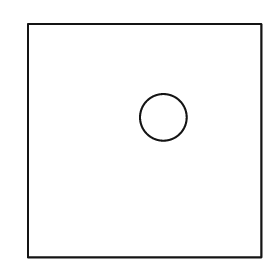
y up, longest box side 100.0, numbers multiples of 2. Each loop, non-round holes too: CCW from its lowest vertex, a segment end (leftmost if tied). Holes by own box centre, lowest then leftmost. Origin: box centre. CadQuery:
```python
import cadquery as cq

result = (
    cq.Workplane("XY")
    .moveTo(-50.0, -50.0)
    .lineTo(50.0, -50.0)
    .lineTo(50.0, 50.0)
    .lineTo(-50.0, 50.0)
    .close()
    .moveTo(8.0, 10.0)
    .circle(10.0)
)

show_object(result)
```